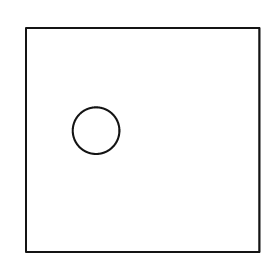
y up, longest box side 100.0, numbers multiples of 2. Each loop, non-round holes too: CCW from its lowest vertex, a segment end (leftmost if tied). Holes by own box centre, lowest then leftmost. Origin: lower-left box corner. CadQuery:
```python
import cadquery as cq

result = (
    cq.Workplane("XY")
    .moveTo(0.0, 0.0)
    .lineTo(100.0, 0.0)
    .lineTo(100.0, 96.0)
    .lineTo(0.0, 96.0)
    .close()
    .moveTo(30.0, 52.0)
    .circle(10.0)
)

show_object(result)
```